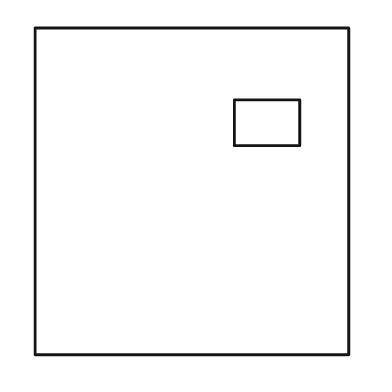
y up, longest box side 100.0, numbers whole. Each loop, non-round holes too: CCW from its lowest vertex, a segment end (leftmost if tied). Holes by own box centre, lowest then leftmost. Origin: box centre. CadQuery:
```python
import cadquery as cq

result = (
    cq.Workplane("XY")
    .moveTo(-48.0, -50.0)
    .lineTo(48.0, -50.0)
    .lineTo(48.0, 50.0)
    .lineTo(-48.0, 50.0)
    .close()
    .moveTo(13.0, 14.0)
    .lineTo(33.0, 14.0)
    .lineTo(33.0, 28.0)
    .lineTo(13.0, 28.0)
    .close()
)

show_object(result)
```